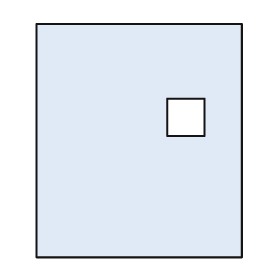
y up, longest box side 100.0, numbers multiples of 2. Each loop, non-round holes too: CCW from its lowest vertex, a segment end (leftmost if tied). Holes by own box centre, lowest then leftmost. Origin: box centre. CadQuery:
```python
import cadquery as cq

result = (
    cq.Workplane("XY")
    .moveTo(-44.0, -50.0)
    .lineTo(44.0, -50.0)
    .lineTo(44.0, 50.0)
    .lineTo(-44.0, 50.0)
    .close()
    .moveTo(12.0, 2.0)
    .lineTo(28.0, 2.0)
    .lineTo(28.0, 18.0)
    .lineTo(12.0, 18.0)
    .close()
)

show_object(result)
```